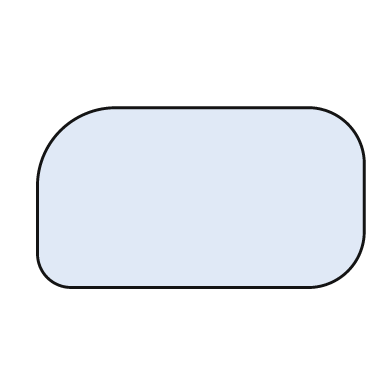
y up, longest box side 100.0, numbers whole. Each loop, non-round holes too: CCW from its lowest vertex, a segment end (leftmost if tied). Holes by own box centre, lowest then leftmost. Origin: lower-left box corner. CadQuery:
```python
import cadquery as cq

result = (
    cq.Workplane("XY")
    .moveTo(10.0, 0.0)
    .lineTo(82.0, 0.0)
    .threePointArc((95.0, 5.0), (100.0, 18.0))
    .lineTo(100.0, 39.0)
    .threePointArc((95.0, 50.0), (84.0, 55.0))
    .lineTo(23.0, 55.0)
    .threePointArc((7.0, 48.0), (0.0, 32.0))
    .lineTo(0.0, 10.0)
    .threePointArc((3.0, 3.0), (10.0, 0.0))
    .close()
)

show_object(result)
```